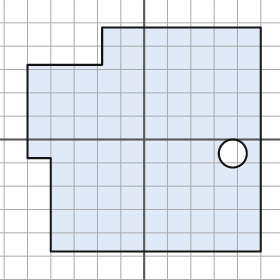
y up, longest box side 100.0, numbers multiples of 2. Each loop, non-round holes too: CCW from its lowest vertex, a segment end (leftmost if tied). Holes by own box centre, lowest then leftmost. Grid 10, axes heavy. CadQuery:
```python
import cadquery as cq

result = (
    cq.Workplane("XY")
    .moveTo(-40.0, -48.0)
    .lineTo(50.0, -48.0)
    .lineTo(50.0, 48.0)
    .lineTo(-18.0, 48.0)
    .lineTo(-18.0, 32.0)
    .lineTo(-50.0, 32.0)
    .lineTo(-50.0, -8.0)
    .lineTo(-40.0, -8.0)
    .close()
    .moveTo(38.0, -6.0)
    .circle(6.0)
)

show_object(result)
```